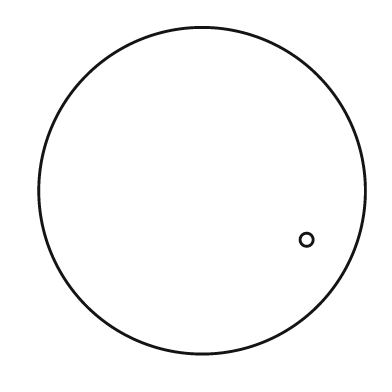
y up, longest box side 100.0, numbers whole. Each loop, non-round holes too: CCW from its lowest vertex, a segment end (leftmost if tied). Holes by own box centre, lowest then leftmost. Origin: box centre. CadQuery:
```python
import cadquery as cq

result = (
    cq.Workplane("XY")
    .moveTo(0.0, 0.0)
    .circle(50.0)
    .moveTo(32.0, -15.0)
    .circle(2.0)
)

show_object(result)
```